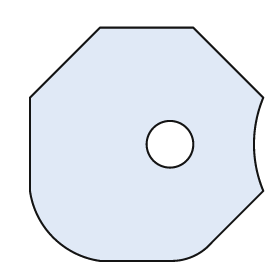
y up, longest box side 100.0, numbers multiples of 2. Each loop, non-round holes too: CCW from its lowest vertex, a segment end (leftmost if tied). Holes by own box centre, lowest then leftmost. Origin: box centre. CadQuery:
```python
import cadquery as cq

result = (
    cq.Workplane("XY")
    .moveTo(-20.0, -50.0)
    .lineTo(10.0, -50.0)
    .threePointArc((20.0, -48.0), (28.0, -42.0))
    .lineTo(50.0, -20.0)
    .threePointArc((46.0, 0.0), (50.0, 20.0))
    .lineTo(20.0, 50.0)
    .lineTo(-20.0, 50.0)
    .lineTo(-50.0, 20.0)
    .lineTo(-50.0, -20.0)
    .threePointArc((-40.0, -40.0), (-20.0, -50.0))
    .close()
    .moveTo(10.0, 0.0)
    .circle(10.0)
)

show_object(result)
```